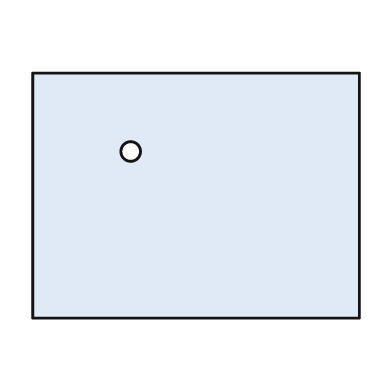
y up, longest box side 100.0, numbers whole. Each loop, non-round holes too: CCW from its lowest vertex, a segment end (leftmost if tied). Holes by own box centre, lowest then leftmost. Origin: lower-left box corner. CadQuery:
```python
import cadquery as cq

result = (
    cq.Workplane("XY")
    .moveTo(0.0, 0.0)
    .lineTo(100.0, 0.0)
    .lineTo(100.0, 75.0)
    .lineTo(0.0, 75.0)
    .close()
    .moveTo(30.0, 51.0)
    .circle(3.0)
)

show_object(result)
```